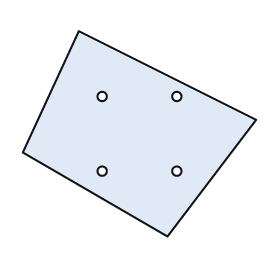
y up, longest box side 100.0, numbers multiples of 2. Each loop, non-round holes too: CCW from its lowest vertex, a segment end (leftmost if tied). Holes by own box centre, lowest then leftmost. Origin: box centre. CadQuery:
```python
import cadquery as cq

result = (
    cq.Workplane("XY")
    .moveTo(12.0, -44.0)
    .lineTo(50.0, 6.0)
    .lineTo(-26.0, 44.0)
    .lineTo(-50.0, -8.0)
    .close()
    .moveTo(-16.0, -16.0)
    .circle(2.0)
    .moveTo(16.0, -16.0)
    .circle(2.0)
    .moveTo(-16.0, 16.0)
    .circle(2.0)
    .moveTo(16.0, 16.0)
    .circle(2.0)
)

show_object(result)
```